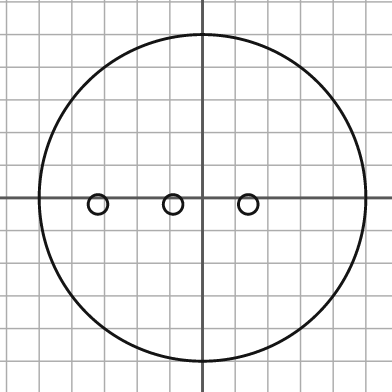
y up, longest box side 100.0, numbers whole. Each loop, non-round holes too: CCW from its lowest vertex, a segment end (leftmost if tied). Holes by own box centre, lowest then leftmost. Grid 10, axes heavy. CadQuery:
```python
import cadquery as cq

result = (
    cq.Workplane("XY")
    .moveTo(0.0, 0.0)
    .circle(50.0)
    .moveTo(-32.0, -2.0)
    .circle(3.0)
    .moveTo(-9.0, -2.0)
    .circle(3.0)
    .moveTo(14.0, -2.0)
    .circle(3.0)
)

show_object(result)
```